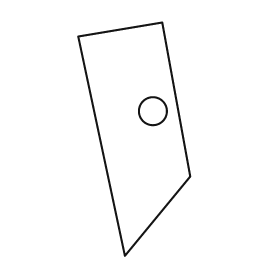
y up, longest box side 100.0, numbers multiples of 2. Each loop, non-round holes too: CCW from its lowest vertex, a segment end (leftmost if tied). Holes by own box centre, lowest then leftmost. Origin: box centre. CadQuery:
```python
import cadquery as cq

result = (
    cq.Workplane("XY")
    .moveTo(-4.0, -50.0)
    .lineTo(24.0, -16.0)
    .lineTo(12.0, 50.0)
    .lineTo(-24.0, 44.0)
    .close()
    .moveTo(8.0, 12.0)
    .circle(6.0)
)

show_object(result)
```